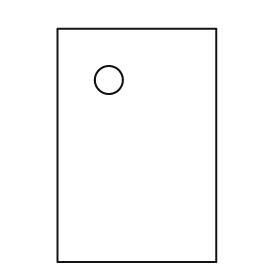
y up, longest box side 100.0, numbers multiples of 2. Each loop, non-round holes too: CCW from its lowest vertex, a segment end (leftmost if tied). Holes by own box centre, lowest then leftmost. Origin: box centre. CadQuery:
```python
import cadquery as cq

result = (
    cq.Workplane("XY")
    .moveTo(-34.0, -50.0)
    .lineTo(34.0, -50.0)
    .lineTo(34.0, 50.0)
    .lineTo(-34.0, 50.0)
    .close()
    .moveTo(-12.0, 28.0)
    .circle(6.0)
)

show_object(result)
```